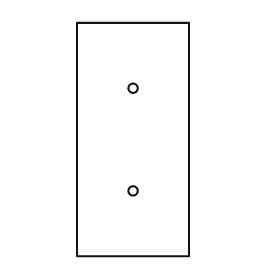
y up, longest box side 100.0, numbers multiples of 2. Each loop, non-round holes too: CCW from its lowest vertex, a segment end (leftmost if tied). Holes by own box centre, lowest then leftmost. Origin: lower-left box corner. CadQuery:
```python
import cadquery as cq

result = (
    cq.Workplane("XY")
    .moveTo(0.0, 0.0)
    .lineTo(48.0, 0.0)
    .lineTo(48.0, 100.0)
    .lineTo(0.0, 100.0)
    .close()
    .moveTo(24.0, 28.0)
    .circle(2.0)
    .moveTo(24.0, 72.0)
    .circle(2.0)
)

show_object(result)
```